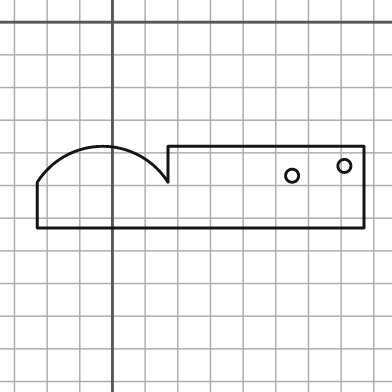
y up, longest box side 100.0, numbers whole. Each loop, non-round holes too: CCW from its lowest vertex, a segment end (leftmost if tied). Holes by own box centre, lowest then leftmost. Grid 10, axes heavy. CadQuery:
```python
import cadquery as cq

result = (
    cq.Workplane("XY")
    .moveTo(-23.0, -63.0)
    .lineTo(77.0, -63.0)
    .lineTo(77.0, -38.0)
    .lineTo(17.0, -38.0)
    .lineTo(17.0, -49.0)
    .threePointArc((-3.0, -38.0), (-23.0, -49.0))
    .close()
    .moveTo(55.0, -47.0)
    .circle(2.0)
    .moveTo(71.0, -44.0)
    .circle(2.0)
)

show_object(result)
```